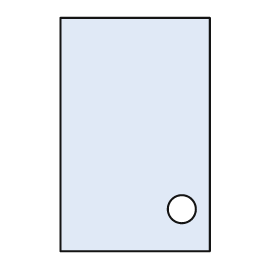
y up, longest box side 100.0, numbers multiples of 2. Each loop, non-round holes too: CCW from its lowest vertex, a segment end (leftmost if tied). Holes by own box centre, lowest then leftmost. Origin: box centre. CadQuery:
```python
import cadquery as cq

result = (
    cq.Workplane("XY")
    .moveTo(-32.0, -50.0)
    .lineTo(32.0, -50.0)
    .lineTo(32.0, 50.0)
    .lineTo(-32.0, 50.0)
    .close()
    .moveTo(20.0, -32.0)
    .circle(6.0)
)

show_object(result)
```